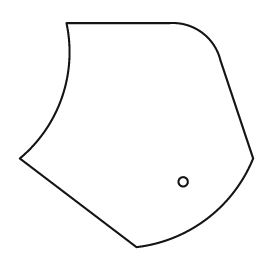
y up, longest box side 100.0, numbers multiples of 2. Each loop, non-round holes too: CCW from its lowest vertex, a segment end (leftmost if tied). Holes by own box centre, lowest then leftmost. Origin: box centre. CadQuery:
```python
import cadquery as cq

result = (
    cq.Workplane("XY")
    .moveTo(0.0, -48.0)
    .threePointArc((30.0, -36.0), (50.0, -10.0))
    .lineTo(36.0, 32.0)
    .threePointArc((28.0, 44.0), (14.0, 48.0))
    .lineTo(-30.0, 48.0)
    .threePointArc((-32.0, 16.0), (-50.0, -10.0))
    .close()
    .moveTo(20.0, -20.0)
    .circle(2.0)
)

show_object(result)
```